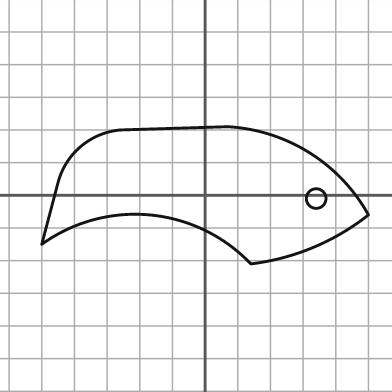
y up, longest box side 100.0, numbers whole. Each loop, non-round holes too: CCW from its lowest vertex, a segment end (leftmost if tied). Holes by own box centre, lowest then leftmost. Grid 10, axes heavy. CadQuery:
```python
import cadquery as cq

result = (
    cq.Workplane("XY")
    .moveTo(14.0, -21.0)
    .threePointArc((33.0, -16.0), (50.0, -6.0))
    .threePointArc((32.0, 13.0), (7.0, 21.0))
    .lineTo(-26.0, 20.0)
    .threePointArc((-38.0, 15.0), (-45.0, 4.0))
    .lineTo(-50.0, -15.0)
    .threePointArc((-17.0, -6.0), (14.0, -21.0))
    .close()
    .moveTo(34.0, -1.0)
    .circle(3.0)
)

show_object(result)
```